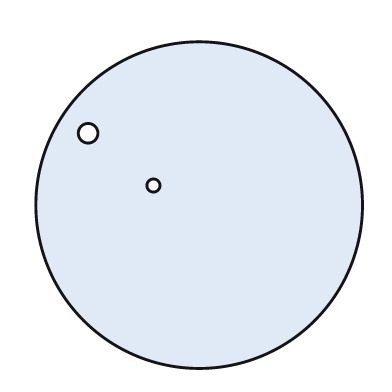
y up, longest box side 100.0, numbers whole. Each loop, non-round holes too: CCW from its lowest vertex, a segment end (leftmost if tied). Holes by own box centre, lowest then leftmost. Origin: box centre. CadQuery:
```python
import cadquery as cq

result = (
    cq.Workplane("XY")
    .moveTo(0.0, 0.0)
    .circle(50.0)
    .moveTo(-14.0, 6.0)
    .circle(2.0)
    .moveTo(-34.0, 22.0)
    .circle(3.0)
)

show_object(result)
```